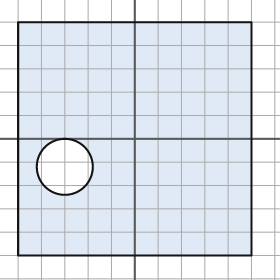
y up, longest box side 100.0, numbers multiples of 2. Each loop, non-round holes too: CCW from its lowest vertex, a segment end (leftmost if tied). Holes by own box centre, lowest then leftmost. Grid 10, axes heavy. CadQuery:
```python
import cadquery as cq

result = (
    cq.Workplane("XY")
    .moveTo(-50.0, -50.0)
    .lineTo(50.0, -50.0)
    .lineTo(50.0, 50.0)
    .lineTo(-50.0, 50.0)
    .close()
    .moveTo(-30.0, -12.0)
    .circle(12.0)
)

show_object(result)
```